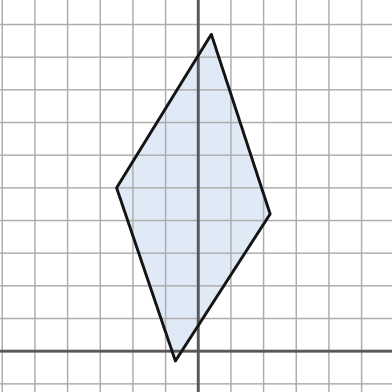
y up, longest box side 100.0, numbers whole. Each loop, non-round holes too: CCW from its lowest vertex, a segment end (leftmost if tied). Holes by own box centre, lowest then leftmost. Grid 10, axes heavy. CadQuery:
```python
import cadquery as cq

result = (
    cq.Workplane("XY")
    .moveTo(-7.0, -3.0)
    .lineTo(22.0, 42.0)
    .lineTo(4.0, 97.0)
    .lineTo(-25.0, 50.0)
    .close()
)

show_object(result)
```